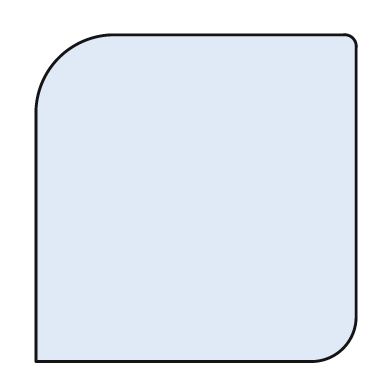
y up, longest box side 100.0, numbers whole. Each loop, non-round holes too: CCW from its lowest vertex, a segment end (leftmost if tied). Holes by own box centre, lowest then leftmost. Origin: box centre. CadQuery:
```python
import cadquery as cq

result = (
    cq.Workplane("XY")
    .moveTo(-49.0, -50.0)
    .lineTo(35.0, -50.0)
    .threePointArc((45.0, -46.0), (49.0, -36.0))
    .lineTo(49.0, 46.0)
    .threePointArc((48.0, 49.0), (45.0, 50.0))
    .lineTo(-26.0, 50.0)
    .threePointArc((-42.0, 43.0), (-49.0, 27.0))
    .close()
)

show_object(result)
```